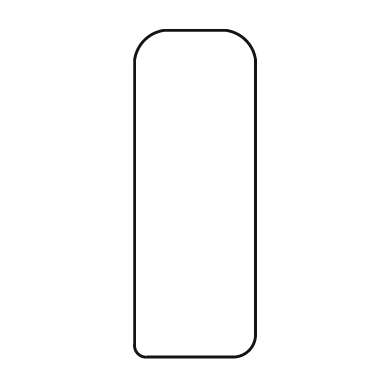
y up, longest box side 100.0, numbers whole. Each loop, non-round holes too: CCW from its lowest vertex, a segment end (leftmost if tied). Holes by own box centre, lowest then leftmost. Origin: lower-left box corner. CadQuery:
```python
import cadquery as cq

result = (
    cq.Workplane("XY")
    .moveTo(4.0, 0.0)
    .lineTo(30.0, 0.0)
    .threePointArc((35.0, 2.0), (37.0, 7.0))
    .lineTo(37.0, 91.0)
    .threePointArc((34.0, 97.0), (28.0, 100.0))
    .lineTo(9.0, 100.0)
    .threePointArc((3.0, 97.0), (0.0, 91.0))
    .lineTo(0.0, 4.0)
    .threePointArc((1.0, 1.0), (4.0, 0.0))
    .close()
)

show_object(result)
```